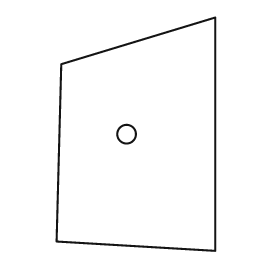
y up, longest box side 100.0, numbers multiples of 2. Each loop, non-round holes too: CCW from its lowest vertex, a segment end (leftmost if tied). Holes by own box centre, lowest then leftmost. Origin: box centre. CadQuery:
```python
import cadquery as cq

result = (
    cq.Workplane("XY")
    .moveTo(34.0, -50.0)
    .lineTo(34.0, 50.0)
    .lineTo(-32.0, 30.0)
    .lineTo(-34.0, -46.0)
    .close()
    .moveTo(-4.0, 0.0)
    .circle(4.0)
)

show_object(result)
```